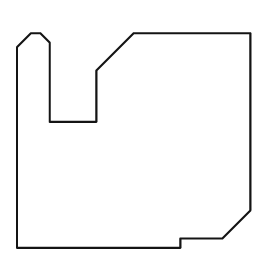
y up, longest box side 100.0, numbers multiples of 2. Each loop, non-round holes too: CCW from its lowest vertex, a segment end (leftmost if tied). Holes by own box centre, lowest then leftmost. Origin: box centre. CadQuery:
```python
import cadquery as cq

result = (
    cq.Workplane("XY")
    .moveTo(-50.0, -46.0)
    .lineTo(20.0, -46.0)
    .lineTo(20.0, -42.0)
    .lineTo(38.0, -42.0)
    .lineTo(50.0, -30.0)
    .lineTo(50.0, 46.0)
    .lineTo(0.0, 46.0)
    .lineTo(-16.0, 30.0)
    .lineTo(-16.0, 8.0)
    .lineTo(-36.0, 8.0)
    .lineTo(-36.0, 42.0)
    .lineTo(-40.0, 46.0)
    .lineTo(-44.0, 46.0)
    .lineTo(-50.0, 40.0)
    .close()
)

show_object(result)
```